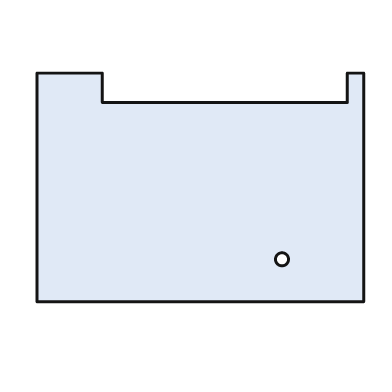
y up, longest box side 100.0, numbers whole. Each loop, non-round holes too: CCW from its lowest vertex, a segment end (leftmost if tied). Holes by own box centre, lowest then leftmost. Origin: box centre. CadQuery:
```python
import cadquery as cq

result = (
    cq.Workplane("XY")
    .moveTo(-50.0, -35.0)
    .lineTo(50.0, -35.0)
    .lineTo(50.0, 35.0)
    .lineTo(45.0, 35.0)
    .lineTo(45.0, 26.0)
    .lineTo(-30.0, 26.0)
    .lineTo(-30.0, 35.0)
    .lineTo(-50.0, 35.0)
    .close()
    .moveTo(25.0, -22.0)
    .circle(2.0)
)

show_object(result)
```